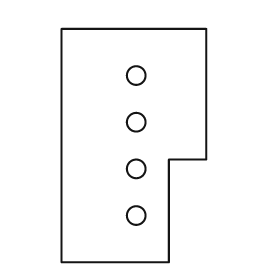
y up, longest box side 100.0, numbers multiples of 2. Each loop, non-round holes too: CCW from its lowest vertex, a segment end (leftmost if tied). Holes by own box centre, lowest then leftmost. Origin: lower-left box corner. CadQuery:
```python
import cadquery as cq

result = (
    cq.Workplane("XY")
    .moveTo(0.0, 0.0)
    .lineTo(46.0, 0.0)
    .lineTo(46.0, 44.0)
    .lineTo(62.0, 44.0)
    .lineTo(62.0, 100.0)
    .lineTo(0.0, 100.0)
    .close()
    .moveTo(32.0, 20.0)
    .circle(4.0)
    .moveTo(32.0, 40.0)
    .circle(4.0)
    .moveTo(32.0, 60.0)
    .circle(4.0)
    .moveTo(32.0, 80.0)
    .circle(4.0)
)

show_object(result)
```